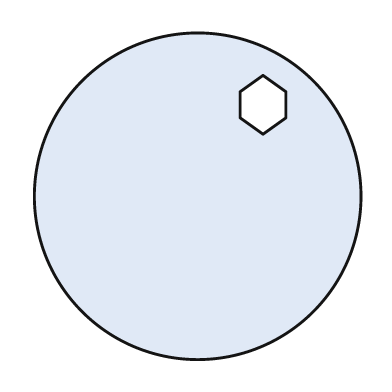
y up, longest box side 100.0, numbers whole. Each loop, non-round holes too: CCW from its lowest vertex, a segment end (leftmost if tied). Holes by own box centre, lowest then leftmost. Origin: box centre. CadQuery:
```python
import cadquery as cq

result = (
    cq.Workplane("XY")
    .moveTo(0.0, 0.0)
    .circle(50.0)
    .moveTo(20.0, 19.0)
    .lineTo(27.0, 24.0)
    .lineTo(27.0, 32.0)
    .lineTo(20.0, 37.0)
    .lineTo(13.0, 32.0)
    .lineTo(13.0, 24.0)
    .close()
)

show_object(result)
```